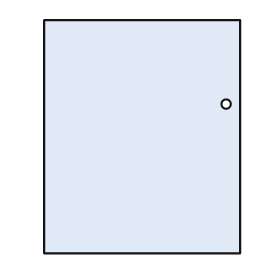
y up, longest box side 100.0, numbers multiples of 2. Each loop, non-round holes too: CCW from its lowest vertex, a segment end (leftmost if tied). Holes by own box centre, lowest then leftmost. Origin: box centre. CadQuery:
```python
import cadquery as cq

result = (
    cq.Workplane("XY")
    .moveTo(-42.0, -50.0)
    .lineTo(42.0, -50.0)
    .lineTo(42.0, 50.0)
    .lineTo(-42.0, 50.0)
    .close()
    .moveTo(36.0, 14.0)
    .circle(2.0)
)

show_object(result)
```